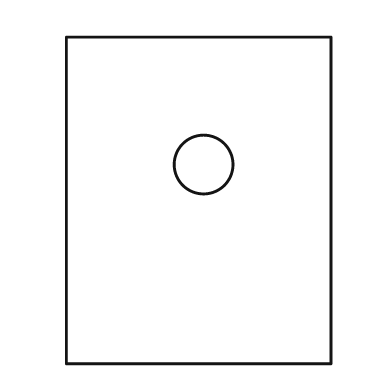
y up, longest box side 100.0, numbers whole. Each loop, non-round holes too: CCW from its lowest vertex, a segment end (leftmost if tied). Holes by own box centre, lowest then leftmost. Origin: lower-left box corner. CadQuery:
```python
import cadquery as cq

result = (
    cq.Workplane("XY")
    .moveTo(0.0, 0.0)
    .lineTo(81.0, 0.0)
    .lineTo(81.0, 100.0)
    .lineTo(0.0, 100.0)
    .close()
    .moveTo(42.0, 61.0)
    .circle(9.0)
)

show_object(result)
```